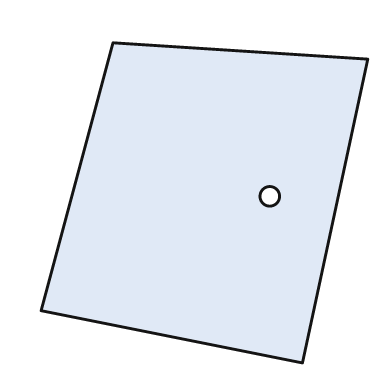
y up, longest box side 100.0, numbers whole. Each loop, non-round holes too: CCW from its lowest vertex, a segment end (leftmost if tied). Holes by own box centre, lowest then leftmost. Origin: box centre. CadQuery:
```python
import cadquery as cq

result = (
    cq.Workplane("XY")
    .moveTo(30.0, -49.0)
    .lineTo(50.0, 44.0)
    .lineTo(-28.0, 49.0)
    .lineTo(-50.0, -33.0)
    .close()
    .moveTo(20.0, 2.0)
    .circle(3.0)
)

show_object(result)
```